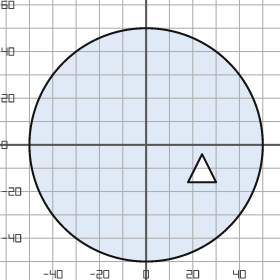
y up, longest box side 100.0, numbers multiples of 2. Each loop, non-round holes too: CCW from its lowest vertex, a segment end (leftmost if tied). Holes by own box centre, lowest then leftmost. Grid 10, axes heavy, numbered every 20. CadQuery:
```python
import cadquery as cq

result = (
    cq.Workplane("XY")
    .moveTo(0.0, 0.0)
    .circle(50.0)
    .moveTo(18.0, -16.0)
    .lineTo(30.0, -16.0)
    .lineTo(24.0, -4.0)
    .close()
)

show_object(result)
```